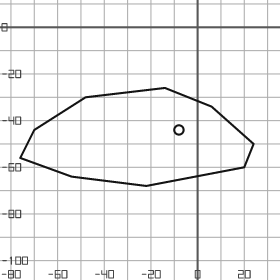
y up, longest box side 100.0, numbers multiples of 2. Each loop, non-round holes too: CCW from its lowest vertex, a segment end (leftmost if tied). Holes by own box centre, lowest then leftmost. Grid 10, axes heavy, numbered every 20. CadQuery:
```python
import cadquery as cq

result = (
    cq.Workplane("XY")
    .moveTo(-22.0, -68.0)
    .lineTo(20.0, -60.0)
    .lineTo(24.0, -50.0)
    .lineTo(6.0, -34.0)
    .lineTo(-14.0, -26.0)
    .lineTo(-48.0, -30.0)
    .lineTo(-70.0, -44.0)
    .lineTo(-76.0, -56.0)
    .lineTo(-54.0, -64.0)
    .close()
    .moveTo(-8.0, -44.0)
    .circle(2.0)
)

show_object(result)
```